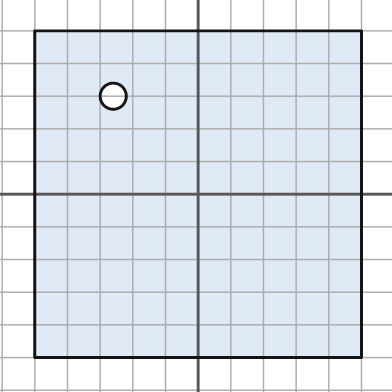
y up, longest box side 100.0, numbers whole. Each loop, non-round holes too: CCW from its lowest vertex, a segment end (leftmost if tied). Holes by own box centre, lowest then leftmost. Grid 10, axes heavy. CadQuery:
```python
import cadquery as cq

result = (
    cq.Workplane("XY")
    .moveTo(-50.0, -50.0)
    .lineTo(50.0, -50.0)
    .lineTo(50.0, 50.0)
    .lineTo(-50.0, 50.0)
    .close()
    .moveTo(-26.0, 30.0)
    .circle(4.0)
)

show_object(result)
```